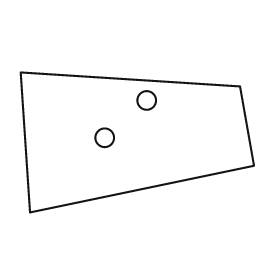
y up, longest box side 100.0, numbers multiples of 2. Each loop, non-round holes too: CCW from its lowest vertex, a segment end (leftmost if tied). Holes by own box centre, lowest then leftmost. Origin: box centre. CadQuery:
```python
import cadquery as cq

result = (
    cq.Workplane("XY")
    .moveTo(-46.0, -30.0)
    .lineTo(50.0, -10.0)
    .lineTo(44.0, 24.0)
    .lineTo(-50.0, 30.0)
    .close()
    .moveTo(-14.0, 2.0)
    .circle(4.0)
    .moveTo(4.0, 18.0)
    .circle(4.0)
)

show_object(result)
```